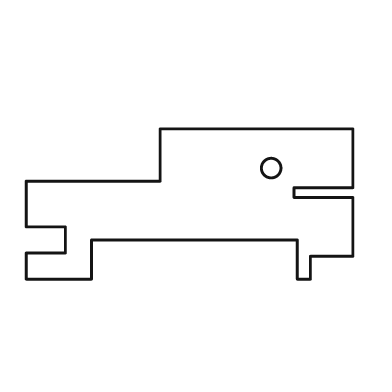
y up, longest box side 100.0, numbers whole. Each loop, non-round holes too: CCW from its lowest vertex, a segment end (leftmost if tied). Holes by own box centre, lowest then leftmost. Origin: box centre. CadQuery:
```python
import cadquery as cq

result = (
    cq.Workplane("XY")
    .moveTo(-50.0, -23.0)
    .lineTo(-30.0, -23.0)
    .lineTo(-30.0, -11.0)
    .lineTo(33.0, -11.0)
    .lineTo(33.0, -23.0)
    .lineTo(37.0, -23.0)
    .lineTo(37.0, -16.0)
    .lineTo(50.0, -16.0)
    .lineTo(50.0, 2.0)
    .lineTo(32.0, 2.0)
    .lineTo(32.0, 5.0)
    .lineTo(50.0, 5.0)
    .lineTo(50.0, 23.0)
    .lineTo(-9.0, 23.0)
    .lineTo(-9.0, 7.0)
    .lineTo(-50.0, 7.0)
    .lineTo(-50.0, -7.0)
    .lineTo(-38.0, -7.0)
    .lineTo(-38.0, -15.0)
    .lineTo(-50.0, -15.0)
    .close()
    .moveTo(25.0, 11.0)
    .circle(3.0)
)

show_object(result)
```